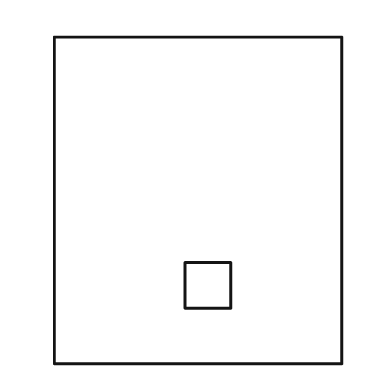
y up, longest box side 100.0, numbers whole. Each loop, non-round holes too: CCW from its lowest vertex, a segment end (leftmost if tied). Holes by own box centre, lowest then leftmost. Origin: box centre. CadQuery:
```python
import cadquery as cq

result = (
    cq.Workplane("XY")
    .moveTo(-44.0, -50.0)
    .lineTo(44.0, -50.0)
    .lineTo(44.0, 50.0)
    .lineTo(-44.0, 50.0)
    .close()
    .moveTo(-4.0, -33.0)
    .lineTo(10.0, -33.0)
    .lineTo(10.0, -19.0)
    .lineTo(-4.0, -19.0)
    .close()
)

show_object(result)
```